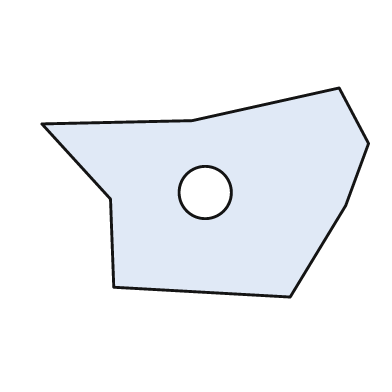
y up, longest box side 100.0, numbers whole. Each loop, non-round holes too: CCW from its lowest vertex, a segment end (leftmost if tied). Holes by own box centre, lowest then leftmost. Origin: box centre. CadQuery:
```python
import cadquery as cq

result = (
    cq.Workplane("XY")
    .moveTo(26.0, -32.0)
    .lineTo(43.0, -4.0)
    .lineTo(50.0, 15.0)
    .lineTo(41.0, 32.0)
    .lineTo(-4.0, 22.0)
    .lineTo(-50.0, 21.0)
    .lineTo(-29.0, -2.0)
    .lineTo(-28.0, -29.0)
    .close()
    .moveTo(0.0, 0.0)
    .circle(8.0)
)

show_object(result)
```